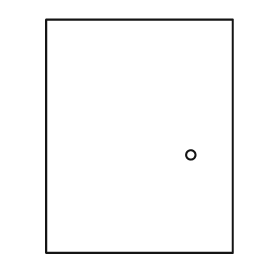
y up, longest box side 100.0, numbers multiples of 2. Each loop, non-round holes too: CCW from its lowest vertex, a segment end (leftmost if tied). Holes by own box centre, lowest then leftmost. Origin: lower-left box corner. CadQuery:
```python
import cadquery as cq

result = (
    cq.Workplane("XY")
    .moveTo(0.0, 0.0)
    .lineTo(80.0, 0.0)
    .lineTo(80.0, 100.0)
    .lineTo(0.0, 100.0)
    .close()
    .moveTo(62.0, 42.0)
    .circle(2.0)
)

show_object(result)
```